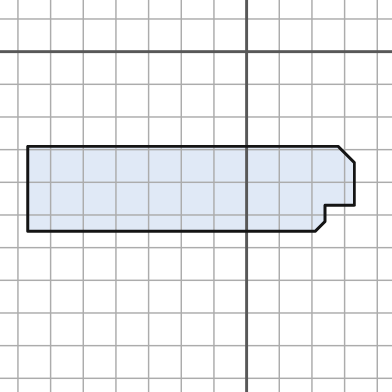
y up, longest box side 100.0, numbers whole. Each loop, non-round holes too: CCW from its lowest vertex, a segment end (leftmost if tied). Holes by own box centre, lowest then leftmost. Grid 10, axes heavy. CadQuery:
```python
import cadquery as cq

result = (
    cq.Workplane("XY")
    .moveTo(-67.0, -55.0)
    .lineTo(21.0, -55.0)
    .lineTo(24.0, -52.0)
    .lineTo(24.0, -47.0)
    .lineTo(33.0, -47.0)
    .lineTo(33.0, -34.0)
    .lineTo(28.0, -29.0)
    .lineTo(-67.0, -29.0)
    .close()
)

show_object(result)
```